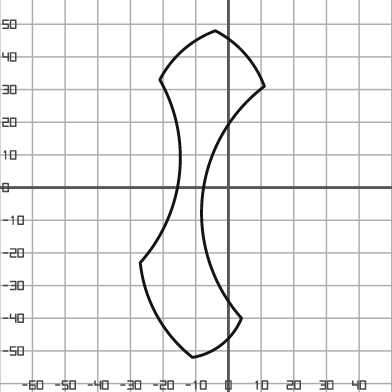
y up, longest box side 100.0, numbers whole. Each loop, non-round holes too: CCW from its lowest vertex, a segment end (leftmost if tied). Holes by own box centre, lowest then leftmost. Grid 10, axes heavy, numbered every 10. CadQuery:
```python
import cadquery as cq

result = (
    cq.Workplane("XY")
    .moveTo(-11.0, -52.0)
    .threePointArc((-2.0, -48.0), (4.0, -40.0))
    .threePointArc((-8.0, -3.0), (11.0, 31.0))
    .threePointArc((5.0, 41.0), (-4.0, 48.0))
    .threePointArc((-14.0, 42.0), (-21.0, 33.0))
    .threePointArc((-15.0, 4.0), (-27.0, -23.0))
    .threePointArc((-22.0, -39.0), (-11.0, -52.0))
    .close()
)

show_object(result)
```